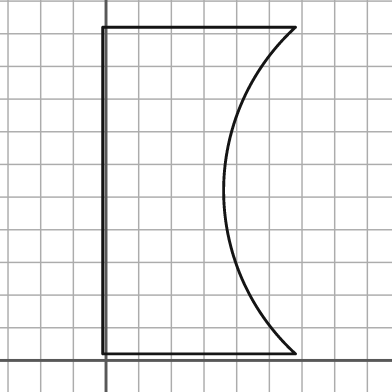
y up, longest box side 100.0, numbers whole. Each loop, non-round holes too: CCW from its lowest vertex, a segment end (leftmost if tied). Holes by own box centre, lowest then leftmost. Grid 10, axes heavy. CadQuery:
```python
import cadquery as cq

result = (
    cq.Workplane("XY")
    .moveTo(-1.0, 2.0)
    .lineTo(58.0, 2.0)
    .threePointArc((36.0, 52.0), (58.0, 102.0))
    .lineTo(-1.0, 102.0)
    .close()
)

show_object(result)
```